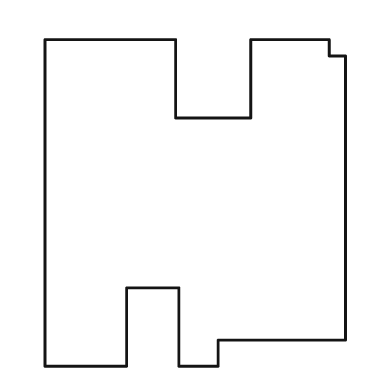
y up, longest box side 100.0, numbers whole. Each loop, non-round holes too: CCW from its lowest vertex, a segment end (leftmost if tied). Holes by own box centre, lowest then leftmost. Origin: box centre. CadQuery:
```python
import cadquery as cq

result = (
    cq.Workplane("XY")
    .moveTo(-46.0, -50.0)
    .lineTo(-21.0, -50.0)
    .lineTo(-21.0, -26.0)
    .lineTo(-5.0, -26.0)
    .lineTo(-5.0, -50.0)
    .lineTo(7.0, -50.0)
    .lineTo(7.0, -42.0)
    .lineTo(46.0, -42.0)
    .lineTo(46.0, 45.0)
    .lineTo(41.0, 45.0)
    .lineTo(41.0, 50.0)
    .lineTo(17.0, 50.0)
    .lineTo(17.0, 26.0)
    .lineTo(-6.0, 26.0)
    .lineTo(-6.0, 50.0)
    .lineTo(-46.0, 50.0)
    .close()
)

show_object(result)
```